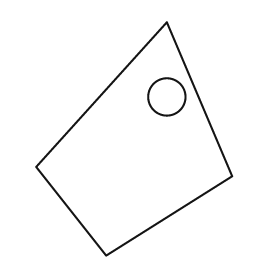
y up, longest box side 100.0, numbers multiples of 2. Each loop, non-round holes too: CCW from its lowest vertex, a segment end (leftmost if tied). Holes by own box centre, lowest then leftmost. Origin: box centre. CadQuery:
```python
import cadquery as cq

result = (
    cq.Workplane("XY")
    .moveTo(-12.0, -50.0)
    .lineTo(42.0, -16.0)
    .lineTo(14.0, 50.0)
    .lineTo(-42.0, -12.0)
    .close()
    .moveTo(14.0, 18.0)
    .circle(8.0)
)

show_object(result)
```